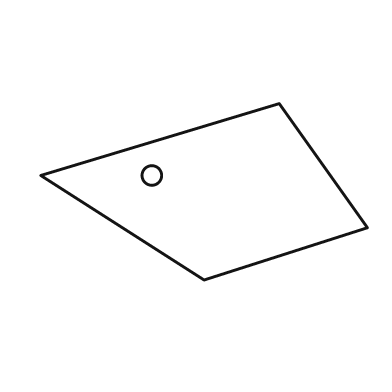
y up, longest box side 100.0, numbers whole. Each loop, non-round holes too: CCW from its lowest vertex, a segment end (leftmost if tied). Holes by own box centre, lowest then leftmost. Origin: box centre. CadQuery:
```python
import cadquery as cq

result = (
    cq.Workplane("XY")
    .moveTo(0.0, -27.0)
    .lineTo(50.0, -11.0)
    .lineTo(23.0, 27.0)
    .lineTo(-50.0, 5.0)
    .close()
    .moveTo(-16.0, 5.0)
    .circle(3.0)
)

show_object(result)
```